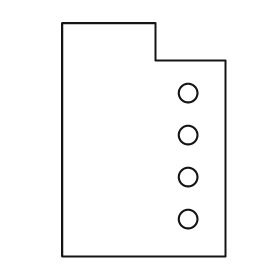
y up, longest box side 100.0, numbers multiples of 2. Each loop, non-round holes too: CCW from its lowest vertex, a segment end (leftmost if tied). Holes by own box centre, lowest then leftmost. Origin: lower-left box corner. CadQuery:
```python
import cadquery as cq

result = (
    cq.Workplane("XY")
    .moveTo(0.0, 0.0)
    .lineTo(70.0, 0.0)
    .lineTo(70.0, 84.0)
    .lineTo(40.0, 84.0)
    .lineTo(40.0, 100.0)
    .lineTo(0.0, 100.0)
    .close()
    .moveTo(54.0, 16.0)
    .circle(4.0)
    .moveTo(54.0, 34.0)
    .circle(4.0)
    .moveTo(54.0, 52.0)
    .circle(4.0)
    .moveTo(54.0, 70.0)
    .circle(4.0)
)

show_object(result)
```